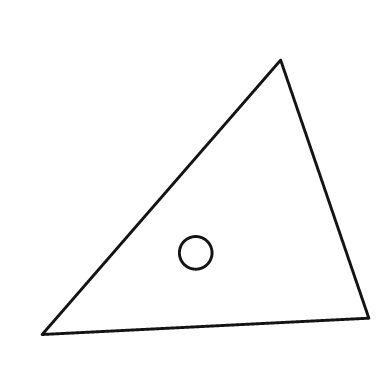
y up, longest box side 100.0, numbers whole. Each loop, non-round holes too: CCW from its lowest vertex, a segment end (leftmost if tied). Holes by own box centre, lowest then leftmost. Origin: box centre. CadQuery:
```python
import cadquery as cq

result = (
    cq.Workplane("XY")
    .moveTo(-50.0, -42.0)
    .lineTo(50.0, -37.0)
    .lineTo(23.0, 42.0)
    .close()
    .moveTo(-3.0, -17.0)
    .circle(5.0)
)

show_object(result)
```